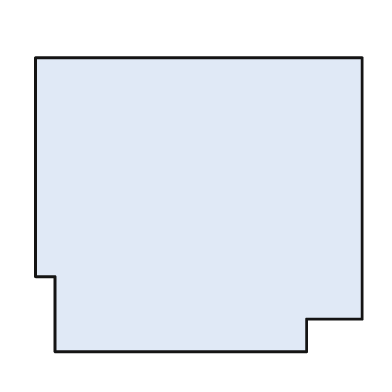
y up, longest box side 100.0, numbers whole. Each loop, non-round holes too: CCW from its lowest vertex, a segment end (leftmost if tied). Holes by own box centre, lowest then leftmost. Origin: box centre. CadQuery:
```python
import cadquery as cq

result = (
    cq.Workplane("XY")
    .moveTo(-44.0, -45.0)
    .lineTo(33.0, -45.0)
    .lineTo(33.0, -35.0)
    .lineTo(50.0, -35.0)
    .lineTo(50.0, 45.0)
    .lineTo(-50.0, 45.0)
    .lineTo(-50.0, -22.0)
    .lineTo(-44.0, -22.0)
    .close()
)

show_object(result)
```